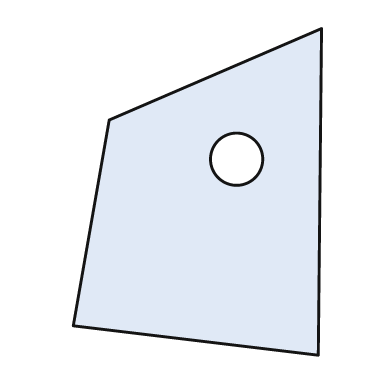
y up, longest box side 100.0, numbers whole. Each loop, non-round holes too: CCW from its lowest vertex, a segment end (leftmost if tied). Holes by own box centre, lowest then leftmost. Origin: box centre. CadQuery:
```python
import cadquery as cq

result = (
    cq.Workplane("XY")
    .moveTo(37.0, -50.0)
    .lineTo(38.0, 50.0)
    .lineTo(-27.0, 22.0)
    .lineTo(-38.0, -41.0)
    .close()
    .moveTo(12.0, 10.0)
    .circle(8.0)
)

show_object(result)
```